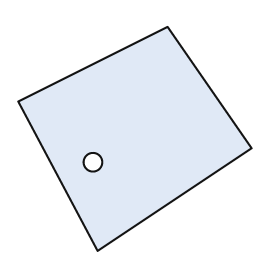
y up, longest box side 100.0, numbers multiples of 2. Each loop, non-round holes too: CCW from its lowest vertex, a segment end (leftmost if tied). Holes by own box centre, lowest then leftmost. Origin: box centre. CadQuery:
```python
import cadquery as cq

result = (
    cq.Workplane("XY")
    .moveTo(-16.0, -48.0)
    .lineTo(50.0, -4.0)
    .lineTo(14.0, 48.0)
    .lineTo(-50.0, 16.0)
    .close()
    .moveTo(-18.0, -10.0)
    .circle(4.0)
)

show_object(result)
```